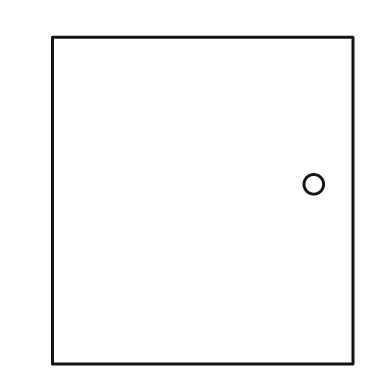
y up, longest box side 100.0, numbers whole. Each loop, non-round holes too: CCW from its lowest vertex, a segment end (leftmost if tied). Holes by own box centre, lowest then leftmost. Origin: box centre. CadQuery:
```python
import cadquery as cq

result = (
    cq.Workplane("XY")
    .moveTo(-46.0, -50.0)
    .lineTo(46.0, -50.0)
    .lineTo(46.0, 50.0)
    .lineTo(-46.0, 50.0)
    .close()
    .moveTo(34.0, 5.0)
    .circle(3.0)
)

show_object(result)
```